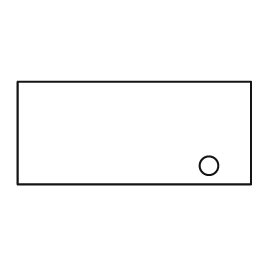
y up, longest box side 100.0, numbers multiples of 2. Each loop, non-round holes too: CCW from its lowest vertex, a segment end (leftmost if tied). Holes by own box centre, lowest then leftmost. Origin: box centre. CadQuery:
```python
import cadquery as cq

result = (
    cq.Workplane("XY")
    .moveTo(-50.0, -22.0)
    .lineTo(50.0, -22.0)
    .lineTo(50.0, 22.0)
    .lineTo(-50.0, 22.0)
    .close()
    .moveTo(32.0, -14.0)
    .circle(4.0)
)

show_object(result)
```